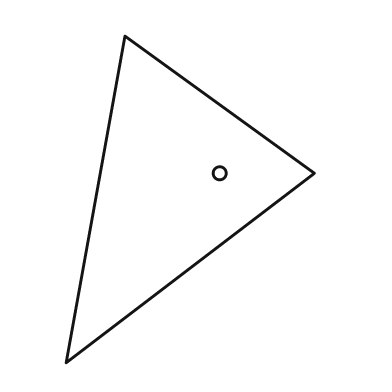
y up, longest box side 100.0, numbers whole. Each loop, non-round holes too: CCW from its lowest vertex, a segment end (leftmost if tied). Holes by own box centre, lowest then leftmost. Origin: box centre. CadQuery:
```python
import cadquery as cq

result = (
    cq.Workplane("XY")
    .moveTo(-38.0, -50.0)
    .lineTo(38.0, 8.0)
    .lineTo(-20.0, 50.0)
    .close()
    .moveTo(9.0, 8.0)
    .circle(2.0)
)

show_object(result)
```